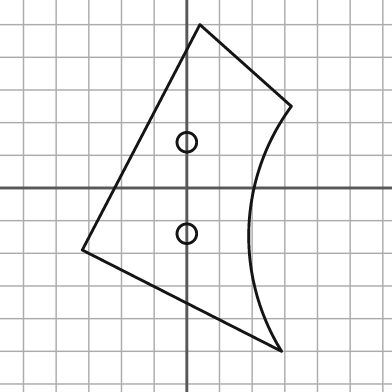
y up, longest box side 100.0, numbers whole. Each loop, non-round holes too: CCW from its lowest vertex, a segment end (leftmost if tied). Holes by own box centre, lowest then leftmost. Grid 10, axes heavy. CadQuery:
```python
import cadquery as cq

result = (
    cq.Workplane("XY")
    .moveTo(29.0, -50.0)
    .threePointArc((19.0, -12.0), (32.0, 25.0))
    .lineTo(4.0, 50.0)
    .lineTo(-32.0, -19.0)
    .close()
    .moveTo(0.0, -14.0)
    .circle(3.0)
    .moveTo(0.0, 14.0)
    .circle(3.0)
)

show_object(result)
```